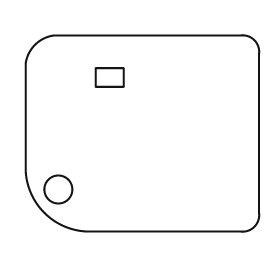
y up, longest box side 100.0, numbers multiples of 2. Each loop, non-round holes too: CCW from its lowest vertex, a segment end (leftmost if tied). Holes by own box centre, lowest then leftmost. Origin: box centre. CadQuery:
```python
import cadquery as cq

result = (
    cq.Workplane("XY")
    .moveTo(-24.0, -42.0)
    .lineTo(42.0, -42.0)
    .threePointArc((48.0, -40.0), (50.0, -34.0))
    .lineTo(50.0, 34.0)
    .threePointArc((48.0, 40.0), (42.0, 42.0))
    .lineTo(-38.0, 42.0)
    .threePointArc((-46.0, 38.0), (-50.0, 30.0))
    .lineTo(-50.0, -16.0)
    .threePointArc((-42.0, -34.0), (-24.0, -42.0))
    .close()
    .moveTo(-36.0, -24.0)
    .circle(6.0)
    .moveTo(-20.0, 20.0)
    .lineTo(-8.0, 20.0)
    .lineTo(-8.0, 28.0)
    .lineTo(-20.0, 28.0)
    .close()
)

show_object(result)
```